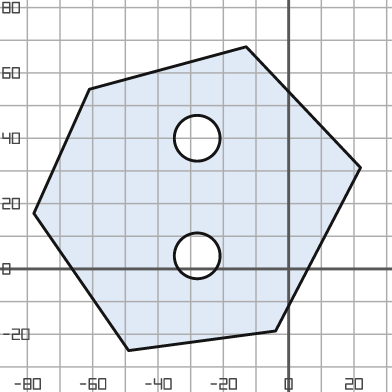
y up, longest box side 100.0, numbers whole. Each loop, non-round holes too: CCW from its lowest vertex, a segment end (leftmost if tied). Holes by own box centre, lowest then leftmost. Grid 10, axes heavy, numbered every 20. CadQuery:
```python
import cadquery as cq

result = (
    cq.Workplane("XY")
    .moveTo(-49.0, -25.0)
    .lineTo(-4.0, -19.0)
    .lineTo(22.0, 31.0)
    .lineTo(-13.0, 68.0)
    .lineTo(-61.0, 55.0)
    .lineTo(-78.0, 17.0)
    .close()
    .moveTo(-28.0, 4.0)
    .circle(7.0)
    .moveTo(-28.0, 40.0)
    .circle(7.0)
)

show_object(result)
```